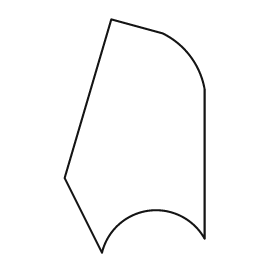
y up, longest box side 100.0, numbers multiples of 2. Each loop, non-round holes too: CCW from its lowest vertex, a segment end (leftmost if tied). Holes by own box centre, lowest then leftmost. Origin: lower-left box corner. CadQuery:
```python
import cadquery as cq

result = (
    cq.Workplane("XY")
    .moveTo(16.0, 0.0)
    .threePointArc((36.0, 18.0), (60.0, 6.0))
    .lineTo(60.0, 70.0)
    .threePointArc((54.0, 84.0), (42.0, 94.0))
    .lineTo(20.0, 100.0)
    .lineTo(0.0, 32.0)
    .close()
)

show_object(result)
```